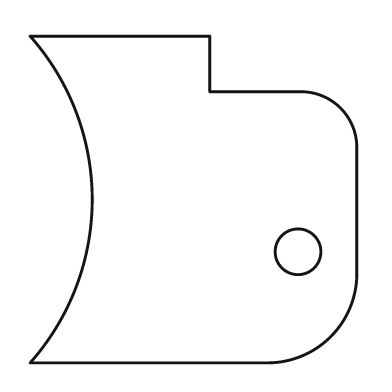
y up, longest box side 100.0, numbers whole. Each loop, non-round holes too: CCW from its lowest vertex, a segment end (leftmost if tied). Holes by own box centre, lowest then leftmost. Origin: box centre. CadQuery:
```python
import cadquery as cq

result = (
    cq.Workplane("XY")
    .moveTo(-50.0, -50.0)
    .lineTo(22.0, -50.0)
    .threePointArc((42.0, -42.0), (50.0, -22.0))
    .lineTo(50.0, 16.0)
    .threePointArc((45.0, 28.0), (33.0, 33.0))
    .lineTo(5.0, 33.0)
    .lineTo(5.0, 50.0)
    .lineTo(-50.0, 50.0)
    .threePointArc((-31.0, 0.0), (-50.0, -50.0))
    .close()
    .moveTo(32.0, -16.0)
    .circle(7.0)
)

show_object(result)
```